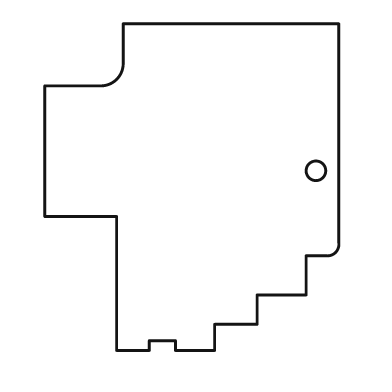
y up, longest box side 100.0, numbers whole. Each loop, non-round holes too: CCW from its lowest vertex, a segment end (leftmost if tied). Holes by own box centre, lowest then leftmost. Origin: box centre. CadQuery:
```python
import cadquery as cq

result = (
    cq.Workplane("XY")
    .moveTo(-23.0, -50.0)
    .lineTo(-13.0, -50.0)
    .lineTo(-13.0, -47.0)
    .lineTo(-5.0, -47.0)
    .lineTo(-5.0, -50.0)
    .lineTo(7.0, -50.0)
    .lineTo(7.0, -42.0)
    .lineTo(20.0, -42.0)
    .lineTo(20.0, -33.0)
    .lineTo(35.0, -33.0)
    .lineTo(35.0, -21.0)
    .lineTo(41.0, -21.0)
    .threePointArc((44.0, -20.0), (45.0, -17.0))
    .lineTo(45.0, 50.0)
    .lineTo(-21.0, 50.0)
    .lineTo(-21.0, 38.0)
    .threePointArc((-23.0, 33.0), (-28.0, 31.0))
    .lineTo(-45.0, 31.0)
    .lineTo(-45.0, -9.0)
    .lineTo(-23.0, -9.0)
    .close()
    .moveTo(38.0, 5.0)
    .circle(3.0)
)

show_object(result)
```